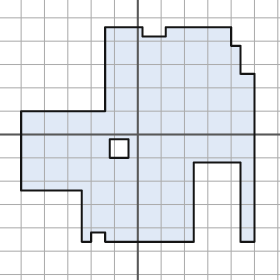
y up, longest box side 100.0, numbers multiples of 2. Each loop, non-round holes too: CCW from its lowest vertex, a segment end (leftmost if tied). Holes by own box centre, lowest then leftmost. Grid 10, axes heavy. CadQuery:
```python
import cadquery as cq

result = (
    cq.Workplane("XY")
    .moveTo(-24.0, -46.0)
    .lineTo(-20.0, -46.0)
    .lineTo(-20.0, -42.0)
    .lineTo(-14.0, -42.0)
    .lineTo(-14.0, -46.0)
    .lineTo(24.0, -46.0)
    .lineTo(24.0, -12.0)
    .lineTo(44.0, -12.0)
    .lineTo(44.0, -46.0)
    .lineTo(50.0, -46.0)
    .lineTo(50.0, 26.0)
    .lineTo(44.0, 26.0)
    .lineTo(44.0, 38.0)
    .lineTo(40.0, 38.0)
    .lineTo(40.0, 46.0)
    .lineTo(12.0, 46.0)
    .lineTo(12.0, 42.0)
    .lineTo(2.0, 42.0)
    .lineTo(2.0, 46.0)
    .lineTo(-14.0, 46.0)
    .lineTo(-14.0, 10.0)
    .lineTo(-50.0, 10.0)
    .lineTo(-50.0, -24.0)
    .lineTo(-24.0, -24.0)
    .close()
    .moveTo(-12.0, -10.0)
    .lineTo(-4.0, -10.0)
    .lineTo(-4.0, -2.0)
    .lineTo(-12.0, -2.0)
    .close()
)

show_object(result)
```